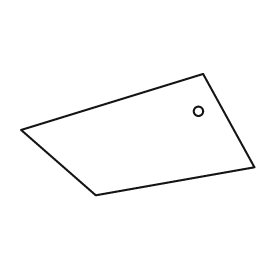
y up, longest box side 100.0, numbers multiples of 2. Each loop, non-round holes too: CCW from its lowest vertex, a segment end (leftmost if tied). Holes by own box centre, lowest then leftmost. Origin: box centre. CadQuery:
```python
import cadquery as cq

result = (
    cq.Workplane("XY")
    .moveTo(-18.0, -26.0)
    .lineTo(50.0, -14.0)
    .lineTo(28.0, 26.0)
    .lineTo(-50.0, 2.0)
    .close()
    .moveTo(26.0, 10.0)
    .circle(2.0)
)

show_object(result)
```